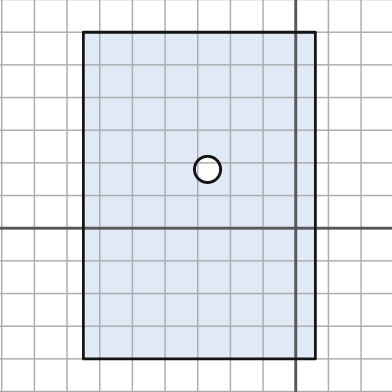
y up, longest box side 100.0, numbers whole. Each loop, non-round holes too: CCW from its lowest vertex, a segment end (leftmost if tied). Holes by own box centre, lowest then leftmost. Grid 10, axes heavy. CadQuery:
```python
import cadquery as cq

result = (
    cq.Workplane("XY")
    .moveTo(-65.0, -40.0)
    .lineTo(6.0, -40.0)
    .lineTo(6.0, 60.0)
    .lineTo(-65.0, 60.0)
    .close()
    .moveTo(-27.0, 18.0)
    .circle(4.0)
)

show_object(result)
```